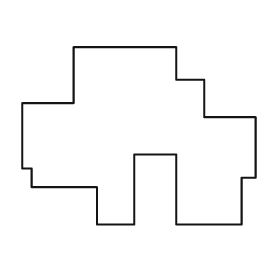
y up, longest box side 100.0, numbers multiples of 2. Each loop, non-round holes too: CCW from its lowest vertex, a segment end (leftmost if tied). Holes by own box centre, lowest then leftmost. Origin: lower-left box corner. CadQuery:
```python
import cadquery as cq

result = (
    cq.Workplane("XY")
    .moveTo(32.0, 0.0)
    .lineTo(48.0, 0.0)
    .lineTo(48.0, 30.0)
    .lineTo(66.0, 30.0)
    .lineTo(66.0, 0.0)
    .lineTo(94.0, 0.0)
    .lineTo(94.0, 20.0)
    .lineTo(100.0, 20.0)
    .lineTo(100.0, 46.0)
    .lineTo(78.0, 46.0)
    .lineTo(78.0, 62.0)
    .lineTo(66.0, 62.0)
    .lineTo(66.0, 76.0)
    .lineTo(22.0, 76.0)
    .lineTo(22.0, 52.0)
    .lineTo(0.0, 52.0)
    .lineTo(0.0, 24.0)
    .lineTo(4.0, 24.0)
    .lineTo(4.0, 16.0)
    .lineTo(32.0, 16.0)
    .close()
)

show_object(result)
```